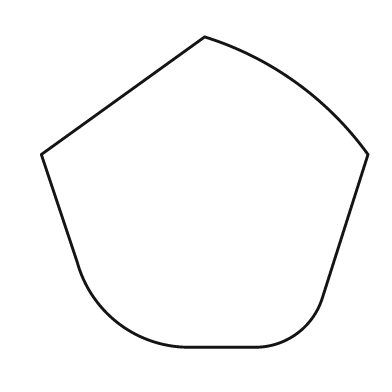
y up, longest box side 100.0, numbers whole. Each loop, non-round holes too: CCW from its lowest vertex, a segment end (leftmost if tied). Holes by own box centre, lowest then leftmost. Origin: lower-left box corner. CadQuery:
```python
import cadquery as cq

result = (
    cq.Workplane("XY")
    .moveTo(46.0, 0.0)
    .lineTo(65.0, 0.0)
    .threePointArc((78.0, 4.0), (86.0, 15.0))
    .lineTo(100.0, 59.0)
    .threePointArc((78.0, 81.0), (50.0, 95.0))
    .lineTo(0.0, 59.0)
    .lineTo(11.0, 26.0)
    .threePointArc((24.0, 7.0), (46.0, 0.0))
    .close()
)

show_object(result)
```